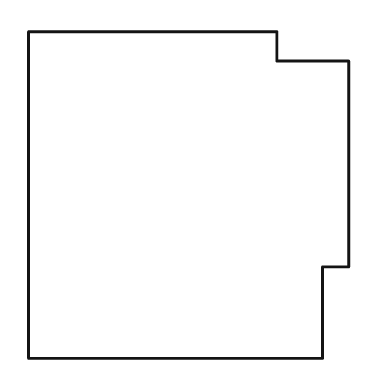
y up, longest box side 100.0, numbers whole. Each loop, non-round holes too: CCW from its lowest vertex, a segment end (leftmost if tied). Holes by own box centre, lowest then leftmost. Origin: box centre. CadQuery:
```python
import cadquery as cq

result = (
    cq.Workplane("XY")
    .moveTo(-49.0, -50.0)
    .lineTo(41.0, -50.0)
    .lineTo(41.0, -22.0)
    .lineTo(49.0, -22.0)
    .lineTo(49.0, 41.0)
    .lineTo(27.0, 41.0)
    .lineTo(27.0, 50.0)
    .lineTo(-49.0, 50.0)
    .close()
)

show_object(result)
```